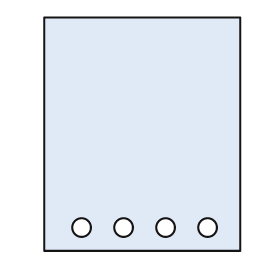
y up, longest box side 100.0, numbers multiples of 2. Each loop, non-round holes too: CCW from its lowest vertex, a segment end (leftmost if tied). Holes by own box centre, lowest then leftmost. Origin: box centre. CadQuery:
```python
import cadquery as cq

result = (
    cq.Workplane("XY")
    .moveTo(-42.0, -50.0)
    .lineTo(42.0, -50.0)
    .lineTo(42.0, 50.0)
    .lineTo(-42.0, 50.0)
    .close()
    .moveTo(-26.0, -40.0)
    .circle(4.0)
    .moveTo(-8.0, -40.0)
    .circle(4.0)
    .moveTo(10.0, -40.0)
    .circle(4.0)
    .moveTo(28.0, -40.0)
    .circle(4.0)
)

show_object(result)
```